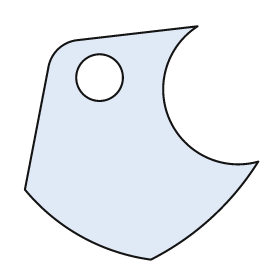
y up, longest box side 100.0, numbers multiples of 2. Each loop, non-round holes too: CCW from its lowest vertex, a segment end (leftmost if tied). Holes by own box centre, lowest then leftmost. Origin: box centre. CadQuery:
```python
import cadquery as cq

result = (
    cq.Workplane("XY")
    .moveTo(4.0, -50.0)
    .threePointArc((30.0, -32.0), (50.0, -8.0))
    .threePointArc((12.0, 10.0), (24.0, 50.0))
    .lineTo(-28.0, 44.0)
    .threePointArc((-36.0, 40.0), (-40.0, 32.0))
    .lineTo(-50.0, -20.0)
    .threePointArc((-26.0, -40.0), (4.0, -50.0))
    .close()
    .moveTo(-18.0, 28.0)
    .circle(10.0)
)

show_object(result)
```